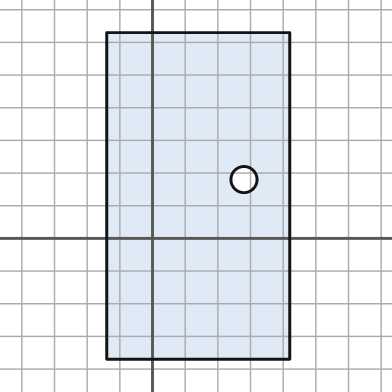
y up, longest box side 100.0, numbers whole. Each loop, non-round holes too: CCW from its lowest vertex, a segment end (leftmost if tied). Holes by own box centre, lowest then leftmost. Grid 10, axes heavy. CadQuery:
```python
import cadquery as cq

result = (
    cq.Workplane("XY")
    .moveTo(-14.0, -37.0)
    .lineTo(42.0, -37.0)
    .lineTo(42.0, 63.0)
    .lineTo(-14.0, 63.0)
    .close()
    .moveTo(28.0, 18.0)
    .circle(4.0)
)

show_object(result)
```